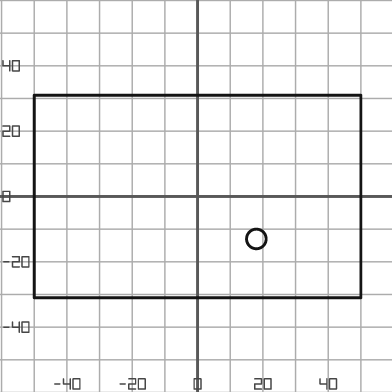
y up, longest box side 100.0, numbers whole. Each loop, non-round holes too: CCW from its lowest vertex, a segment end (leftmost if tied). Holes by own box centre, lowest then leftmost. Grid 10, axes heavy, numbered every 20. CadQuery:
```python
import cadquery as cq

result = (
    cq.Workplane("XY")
    .moveTo(-50.0, -31.0)
    .lineTo(50.0, -31.0)
    .lineTo(50.0, 31.0)
    .lineTo(-50.0, 31.0)
    .close()
    .moveTo(18.0, -13.0)
    .circle(3.0)
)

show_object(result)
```